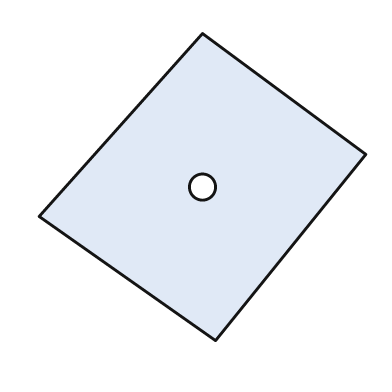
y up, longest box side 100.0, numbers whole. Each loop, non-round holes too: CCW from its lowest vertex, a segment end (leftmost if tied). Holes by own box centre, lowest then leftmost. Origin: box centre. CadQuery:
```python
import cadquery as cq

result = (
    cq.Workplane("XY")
    .moveTo(4.0, -47.0)
    .lineTo(50.0, 10.0)
    .lineTo(0.0, 47.0)
    .lineTo(-50.0, -9.0)
    .close()
    .moveTo(0.0, 0.0)
    .circle(4.0)
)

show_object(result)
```